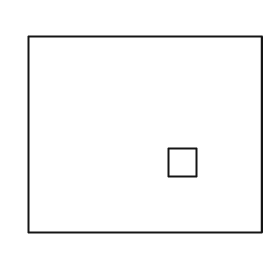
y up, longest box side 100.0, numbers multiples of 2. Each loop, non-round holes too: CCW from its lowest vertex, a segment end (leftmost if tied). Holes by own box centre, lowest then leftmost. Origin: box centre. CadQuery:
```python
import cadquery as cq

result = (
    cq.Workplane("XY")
    .moveTo(-50.0, -42.0)
    .lineTo(50.0, -42.0)
    .lineTo(50.0, 42.0)
    .lineTo(-50.0, 42.0)
    .close()
    .moveTo(10.0, -18.0)
    .lineTo(22.0, -18.0)
    .lineTo(22.0, -6.0)
    .lineTo(10.0, -6.0)
    .close()
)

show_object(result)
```